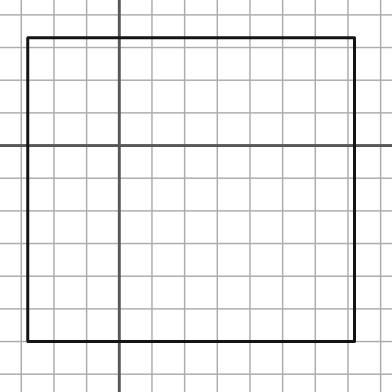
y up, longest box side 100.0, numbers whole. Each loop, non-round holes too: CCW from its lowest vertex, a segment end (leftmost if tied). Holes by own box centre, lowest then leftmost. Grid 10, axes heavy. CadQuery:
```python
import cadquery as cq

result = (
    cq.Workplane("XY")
    .moveTo(-28.0, -60.0)
    .lineTo(72.0, -60.0)
    .lineTo(72.0, 33.0)
    .lineTo(-28.0, 33.0)
    .close()
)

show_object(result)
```